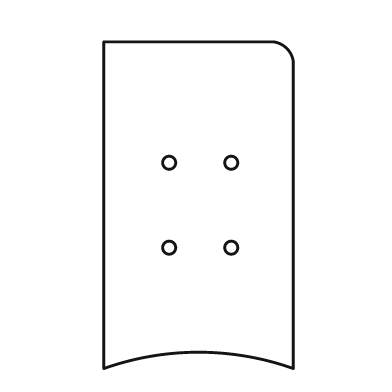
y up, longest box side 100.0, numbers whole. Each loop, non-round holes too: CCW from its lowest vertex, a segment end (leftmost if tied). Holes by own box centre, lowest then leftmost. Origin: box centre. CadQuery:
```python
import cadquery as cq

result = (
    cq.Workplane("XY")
    .moveTo(-29.0, -50.0)
    .threePointArc((0.0, -45.0), (29.0, -50.0))
    .lineTo(29.0, 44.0)
    .threePointArc((27.0, 48.0), (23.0, 50.0))
    .lineTo(-29.0, 50.0)
    .close()
    .moveTo(-9.0, -13.0)
    .circle(2.0)
    .moveTo(10.0, -13.0)
    .circle(2.0)
    .moveTo(-9.0, 13.0)
    .circle(2.0)
    .moveTo(10.0, 13.0)
    .circle(2.0)
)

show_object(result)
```